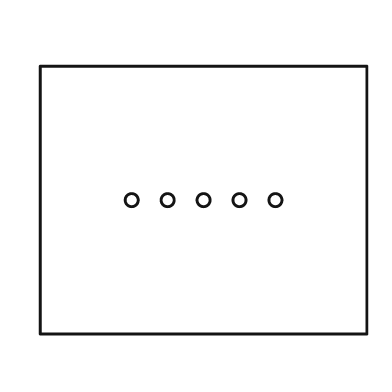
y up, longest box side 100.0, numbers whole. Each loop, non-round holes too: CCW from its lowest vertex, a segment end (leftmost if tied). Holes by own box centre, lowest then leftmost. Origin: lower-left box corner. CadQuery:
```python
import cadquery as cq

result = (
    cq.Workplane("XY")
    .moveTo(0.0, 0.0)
    .lineTo(100.0, 0.0)
    .lineTo(100.0, 82.0)
    .lineTo(0.0, 82.0)
    .close()
    .moveTo(28.0, 41.0)
    .circle(2.0)
    .moveTo(39.0, 41.0)
    .circle(2.0)
    .moveTo(50.0, 41.0)
    .circle(2.0)
    .moveTo(61.0, 41.0)
    .circle(2.0)
    .moveTo(72.0, 41.0)
    .circle(2.0)
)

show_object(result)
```